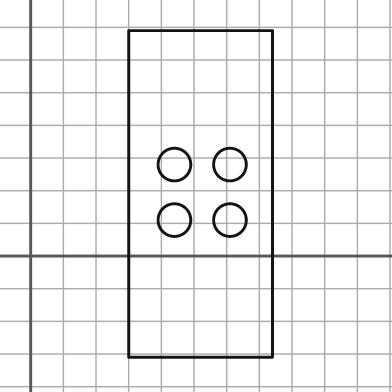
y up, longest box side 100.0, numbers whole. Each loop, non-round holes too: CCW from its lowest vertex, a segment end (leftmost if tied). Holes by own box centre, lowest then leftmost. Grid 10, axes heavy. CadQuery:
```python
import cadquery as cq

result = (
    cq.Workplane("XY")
    .moveTo(30.0, -31.0)
    .lineTo(74.0, -31.0)
    .lineTo(74.0, 69.0)
    .lineTo(30.0, 69.0)
    .close()
    .moveTo(44.0, 11.0)
    .circle(5.0)
    .moveTo(61.0, 11.0)
    .circle(5.0)
    .moveTo(44.0, 28.0)
    .circle(5.0)
    .moveTo(61.0, 28.0)
    .circle(5.0)
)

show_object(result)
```